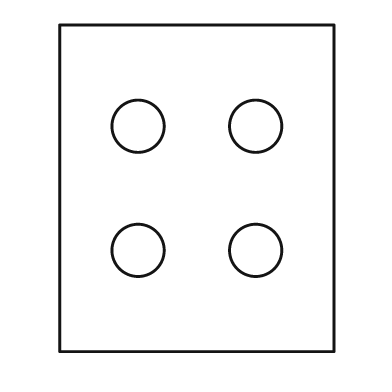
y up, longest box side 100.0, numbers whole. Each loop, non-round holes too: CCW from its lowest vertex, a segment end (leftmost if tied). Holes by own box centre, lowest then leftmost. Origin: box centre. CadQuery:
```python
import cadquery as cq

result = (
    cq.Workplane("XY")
    .moveTo(-42.0, -50.0)
    .lineTo(42.0, -50.0)
    .lineTo(42.0, 50.0)
    .lineTo(-42.0, 50.0)
    .close()
    .moveTo(-18.0, -19.0)
    .circle(8.0)
    .moveTo(18.0, -19.0)
    .circle(8.0)
    .moveTo(-18.0, 19.0)
    .circle(8.0)
    .moveTo(18.0, 19.0)
    .circle(8.0)
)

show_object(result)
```